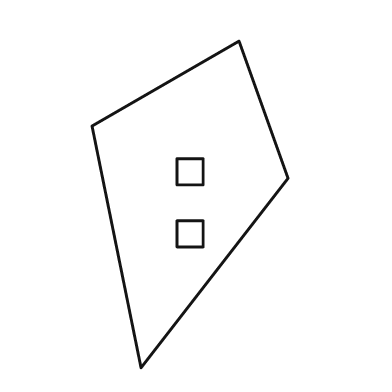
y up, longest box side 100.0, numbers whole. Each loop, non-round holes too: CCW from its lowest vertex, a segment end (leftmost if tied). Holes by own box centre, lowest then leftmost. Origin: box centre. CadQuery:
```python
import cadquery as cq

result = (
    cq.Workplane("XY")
    .moveTo(-15.0, -50.0)
    .lineTo(30.0, 8.0)
    .lineTo(15.0, 50.0)
    .lineTo(-30.0, 24.0)
    .close()
    .moveTo(-4.0, -13.0)
    .lineTo(4.0, -13.0)
    .lineTo(4.0, -5.0)
    .lineTo(-4.0, -5.0)
    .close()
    .moveTo(-4.0, 6.0)
    .lineTo(4.0, 6.0)
    .lineTo(4.0, 14.0)
    .lineTo(-4.0, 14.0)
    .close()
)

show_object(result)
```